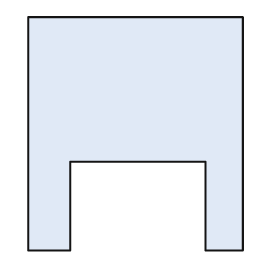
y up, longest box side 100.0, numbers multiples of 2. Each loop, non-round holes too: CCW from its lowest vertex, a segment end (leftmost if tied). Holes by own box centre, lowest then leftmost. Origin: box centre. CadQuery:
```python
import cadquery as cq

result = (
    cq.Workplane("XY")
    .moveTo(-46.0, -50.0)
    .lineTo(-28.0, -50.0)
    .lineTo(-28.0, -12.0)
    .lineTo(30.0, -12.0)
    .lineTo(30.0, -50.0)
    .lineTo(46.0, -50.0)
    .lineTo(46.0, 50.0)
    .lineTo(-46.0, 50.0)
    .close()
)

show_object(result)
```